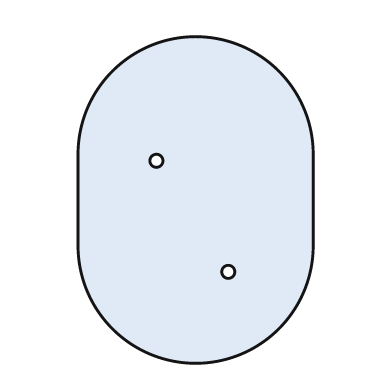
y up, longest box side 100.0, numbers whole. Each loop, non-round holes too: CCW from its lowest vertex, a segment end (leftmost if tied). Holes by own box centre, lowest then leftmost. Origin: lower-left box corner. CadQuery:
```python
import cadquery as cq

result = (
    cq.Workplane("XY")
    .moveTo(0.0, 36.0)
    .threePointArc((36.0, 0.0), (72.0, 36.0))
    .lineTo(72.0, 64.0)
    .threePointArc((36.0, 100.0), (0.0, 64.0))
    .close()
    .moveTo(46.0, 28.0)
    .circle(2.0)
    .moveTo(24.0, 62.0)
    .circle(2.0)
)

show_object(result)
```